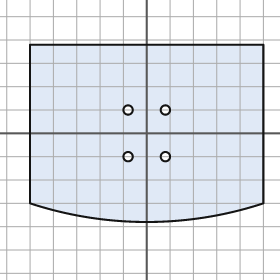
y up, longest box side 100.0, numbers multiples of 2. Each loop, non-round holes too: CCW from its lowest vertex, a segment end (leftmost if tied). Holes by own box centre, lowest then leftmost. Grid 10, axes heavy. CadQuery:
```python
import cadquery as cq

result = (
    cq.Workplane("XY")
    .moveTo(-50.0, -30.0)
    .threePointArc((0.0, -38.0), (50.0, -30.0))
    .lineTo(50.0, 38.0)
    .lineTo(-50.0, 38.0)
    .close()
    .moveTo(-8.0, -10.0)
    .circle(2.0)
    .moveTo(8.0, -10.0)
    .circle(2.0)
    .moveTo(-8.0, 10.0)
    .circle(2.0)
    .moveTo(8.0, 10.0)
    .circle(2.0)
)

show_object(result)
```